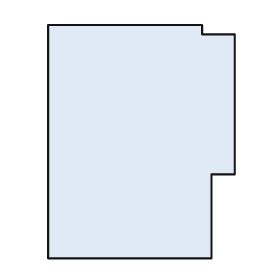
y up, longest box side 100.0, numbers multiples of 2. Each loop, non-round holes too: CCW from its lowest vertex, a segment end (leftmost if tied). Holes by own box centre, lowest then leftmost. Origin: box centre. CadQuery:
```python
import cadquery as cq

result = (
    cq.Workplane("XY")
    .moveTo(-40.0, -50.0)
    .lineTo(30.0, -50.0)
    .lineTo(30.0, -14.0)
    .lineTo(40.0, -14.0)
    .lineTo(40.0, 46.0)
    .lineTo(26.0, 46.0)
    .lineTo(26.0, 50.0)
    .lineTo(-40.0, 50.0)
    .close()
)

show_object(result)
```